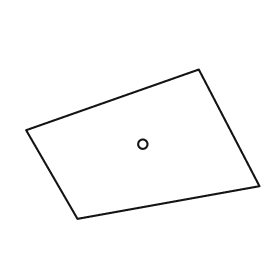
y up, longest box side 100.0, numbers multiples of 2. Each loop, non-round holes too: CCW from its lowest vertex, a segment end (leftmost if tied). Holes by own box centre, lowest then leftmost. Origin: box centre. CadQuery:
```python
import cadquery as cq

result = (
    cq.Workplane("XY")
    .moveTo(-28.0, -32.0)
    .lineTo(50.0, -18.0)
    .lineTo(24.0, 32.0)
    .lineTo(-50.0, 6.0)
    .close()
    .moveTo(0.0, 0.0)
    .circle(2.0)
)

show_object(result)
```